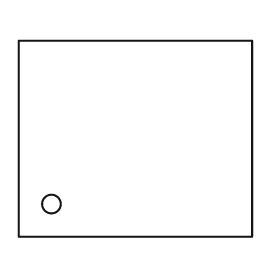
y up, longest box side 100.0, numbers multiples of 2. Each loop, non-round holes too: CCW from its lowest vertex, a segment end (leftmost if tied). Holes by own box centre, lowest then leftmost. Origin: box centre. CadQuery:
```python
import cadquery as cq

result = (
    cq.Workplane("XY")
    .moveTo(-50.0, -42.0)
    .lineTo(50.0, -42.0)
    .lineTo(50.0, 42.0)
    .lineTo(-50.0, 42.0)
    .close()
    .moveTo(-36.0, -28.0)
    .circle(4.0)
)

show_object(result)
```